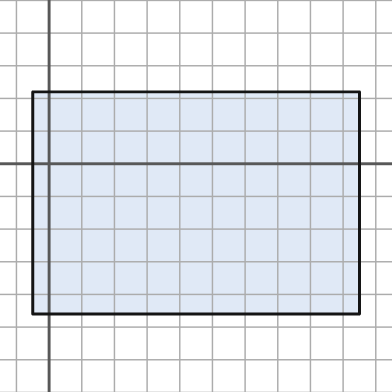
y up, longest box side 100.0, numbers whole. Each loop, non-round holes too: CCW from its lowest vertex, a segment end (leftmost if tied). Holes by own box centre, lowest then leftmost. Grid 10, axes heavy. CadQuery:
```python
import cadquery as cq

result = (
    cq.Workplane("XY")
    .moveTo(-5.0, -46.0)
    .lineTo(95.0, -46.0)
    .lineTo(95.0, 22.0)
    .lineTo(-5.0, 22.0)
    .close()
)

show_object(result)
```